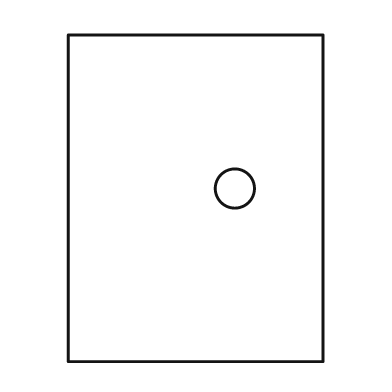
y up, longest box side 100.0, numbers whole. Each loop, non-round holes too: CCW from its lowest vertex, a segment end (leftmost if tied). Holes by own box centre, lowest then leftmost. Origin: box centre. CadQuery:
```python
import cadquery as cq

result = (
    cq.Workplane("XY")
    .moveTo(-39.0, -50.0)
    .lineTo(39.0, -50.0)
    .lineTo(39.0, 50.0)
    .lineTo(-39.0, 50.0)
    .close()
    .moveTo(12.0, 3.0)
    .circle(6.0)
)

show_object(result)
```